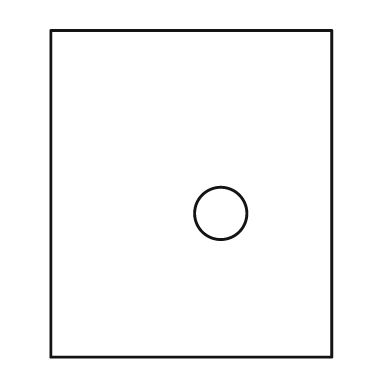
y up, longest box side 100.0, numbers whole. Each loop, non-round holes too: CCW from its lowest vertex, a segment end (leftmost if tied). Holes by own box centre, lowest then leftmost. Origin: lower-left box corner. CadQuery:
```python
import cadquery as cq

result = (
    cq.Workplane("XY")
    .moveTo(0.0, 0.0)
    .lineTo(86.0, 0.0)
    .lineTo(86.0, 100.0)
    .lineTo(0.0, 100.0)
    .close()
    .moveTo(52.0, 44.0)
    .circle(8.0)
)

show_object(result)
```